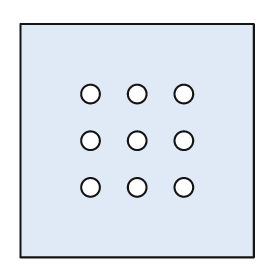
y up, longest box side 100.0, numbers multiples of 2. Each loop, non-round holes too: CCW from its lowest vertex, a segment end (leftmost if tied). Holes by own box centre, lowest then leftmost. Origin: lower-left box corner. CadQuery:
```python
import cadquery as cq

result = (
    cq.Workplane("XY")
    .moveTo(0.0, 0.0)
    .lineTo(100.0, 0.0)
    .lineTo(100.0, 100.0)
    .lineTo(0.0, 100.0)
    .close()
    .moveTo(30.0, 30.0)
    .circle(4.0)
    .moveTo(50.0, 30.0)
    .circle(4.0)
    .moveTo(70.0, 30.0)
    .circle(4.0)
    .moveTo(30.0, 50.0)
    .circle(4.0)
    .moveTo(50.0, 50.0)
    .circle(4.0)
    .moveTo(70.0, 50.0)
    .circle(4.0)
    .moveTo(30.0, 70.0)
    .circle(4.0)
    .moveTo(50.0, 70.0)
    .circle(4.0)
    .moveTo(70.0, 70.0)
    .circle(4.0)
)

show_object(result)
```